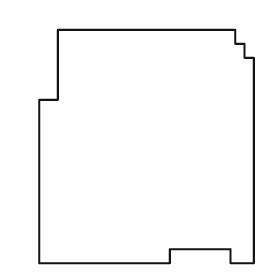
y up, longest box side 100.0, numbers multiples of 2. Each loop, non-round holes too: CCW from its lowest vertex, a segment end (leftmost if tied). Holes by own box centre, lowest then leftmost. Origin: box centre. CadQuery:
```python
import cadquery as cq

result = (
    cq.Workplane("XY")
    .moveTo(-46.0, -50.0)
    .lineTo(10.0, -50.0)
    .lineTo(10.0, -44.0)
    .lineTo(36.0, -44.0)
    .lineTo(36.0, -50.0)
    .lineTo(46.0, -50.0)
    .lineTo(46.0, 38.0)
    .lineTo(42.0, 38.0)
    .lineTo(42.0, 44.0)
    .lineTo(38.0, 44.0)
    .lineTo(38.0, 50.0)
    .lineTo(-38.0, 50.0)
    .lineTo(-38.0, 20.0)
    .lineTo(-46.0, 20.0)
    .close()
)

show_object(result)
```